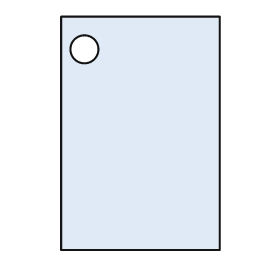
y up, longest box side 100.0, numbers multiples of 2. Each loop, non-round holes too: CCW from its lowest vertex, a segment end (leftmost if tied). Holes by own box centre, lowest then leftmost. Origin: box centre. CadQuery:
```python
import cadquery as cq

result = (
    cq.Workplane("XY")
    .moveTo(-34.0, -50.0)
    .lineTo(34.0, -50.0)
    .lineTo(34.0, 50.0)
    .lineTo(-34.0, 50.0)
    .close()
    .moveTo(-24.0, 36.0)
    .circle(6.0)
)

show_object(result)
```